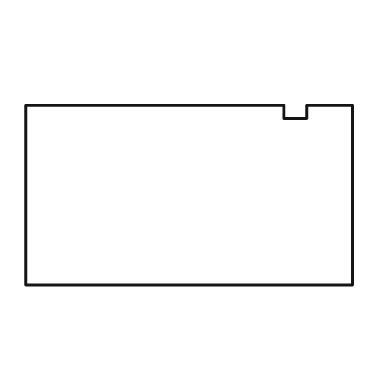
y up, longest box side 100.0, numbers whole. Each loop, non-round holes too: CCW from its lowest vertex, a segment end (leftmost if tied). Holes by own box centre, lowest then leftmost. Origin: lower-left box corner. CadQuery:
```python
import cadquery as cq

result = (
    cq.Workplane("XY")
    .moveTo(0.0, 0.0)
    .lineTo(100.0, 0.0)
    .lineTo(100.0, 55.0)
    .lineTo(86.0, 55.0)
    .lineTo(86.0, 51.0)
    .lineTo(79.0, 51.0)
    .lineTo(79.0, 55.0)
    .lineTo(0.0, 55.0)
    .close()
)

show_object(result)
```